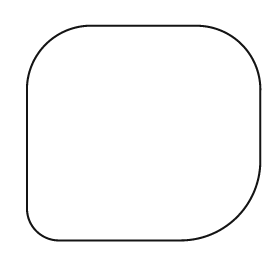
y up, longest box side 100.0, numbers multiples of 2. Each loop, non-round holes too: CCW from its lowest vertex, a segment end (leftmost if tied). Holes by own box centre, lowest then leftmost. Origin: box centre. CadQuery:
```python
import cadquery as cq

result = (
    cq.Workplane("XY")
    .moveTo(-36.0, -46.0)
    .lineTo(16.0, -46.0)
    .threePointArc((40.0, -36.0), (50.0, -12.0))
    .lineTo(50.0, 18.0)
    .threePointArc((42.0, 38.0), (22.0, 46.0))
    .lineTo(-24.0, 46.0)
    .threePointArc((-42.0, 38.0), (-50.0, 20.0))
    .lineTo(-50.0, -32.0)
    .threePointArc((-46.0, -42.0), (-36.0, -46.0))
    .close()
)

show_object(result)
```